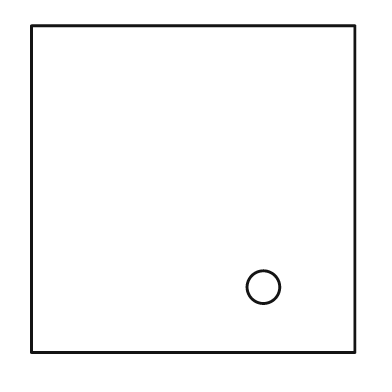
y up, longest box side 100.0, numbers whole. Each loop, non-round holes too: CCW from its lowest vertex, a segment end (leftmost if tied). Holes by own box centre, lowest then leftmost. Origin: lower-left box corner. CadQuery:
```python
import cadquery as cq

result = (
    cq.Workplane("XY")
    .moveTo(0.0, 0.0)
    .lineTo(99.0, 0.0)
    .lineTo(99.0, 100.0)
    .lineTo(0.0, 100.0)
    .close()
    .moveTo(71.0, 20.0)
    .circle(5.0)
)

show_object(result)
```